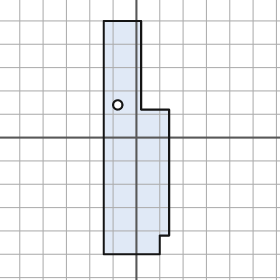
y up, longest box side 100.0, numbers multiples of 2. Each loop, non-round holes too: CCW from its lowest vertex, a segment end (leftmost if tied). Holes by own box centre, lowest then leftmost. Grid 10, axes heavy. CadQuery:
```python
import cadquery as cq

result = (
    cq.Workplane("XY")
    .moveTo(-14.0, -50.0)
    .lineTo(10.0, -50.0)
    .lineTo(10.0, -42.0)
    .lineTo(14.0, -42.0)
    .lineTo(14.0, 12.0)
    .lineTo(2.0, 12.0)
    .lineTo(2.0, 50.0)
    .lineTo(-14.0, 50.0)
    .close()
    .moveTo(-8.0, 14.0)
    .circle(2.0)
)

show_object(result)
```